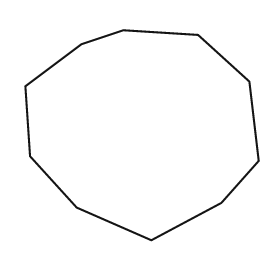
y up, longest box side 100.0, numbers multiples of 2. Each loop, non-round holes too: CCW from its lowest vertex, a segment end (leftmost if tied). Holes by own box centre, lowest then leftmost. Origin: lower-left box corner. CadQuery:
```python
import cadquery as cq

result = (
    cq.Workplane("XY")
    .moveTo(54.0, 0.0)
    .lineTo(84.0, 16.0)
    .lineTo(100.0, 34.0)
    .lineTo(96.0, 68.0)
    .lineTo(74.0, 88.0)
    .lineTo(42.0, 90.0)
    .lineTo(24.0, 84.0)
    .lineTo(0.0, 66.0)
    .lineTo(2.0, 36.0)
    .lineTo(22.0, 14.0)
    .close()
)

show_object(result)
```